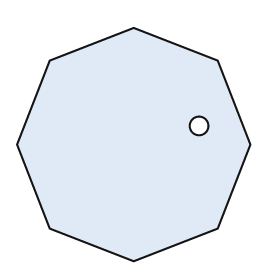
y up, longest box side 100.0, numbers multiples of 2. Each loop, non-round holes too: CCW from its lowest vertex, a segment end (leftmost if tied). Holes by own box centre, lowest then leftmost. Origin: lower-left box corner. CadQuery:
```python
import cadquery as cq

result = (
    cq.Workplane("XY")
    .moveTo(50.0, 0.0)
    .lineTo(86.0, 14.0)
    .lineTo(100.0, 50.0)
    .lineTo(86.0, 86.0)
    .lineTo(50.0, 100.0)
    .lineTo(14.0, 86.0)
    .lineTo(0.0, 50.0)
    .lineTo(14.0, 14.0)
    .close()
    .moveTo(78.0, 58.0)
    .circle(4.0)
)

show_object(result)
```